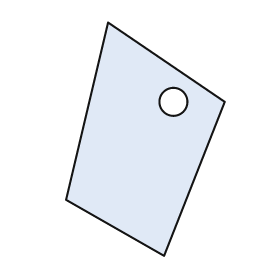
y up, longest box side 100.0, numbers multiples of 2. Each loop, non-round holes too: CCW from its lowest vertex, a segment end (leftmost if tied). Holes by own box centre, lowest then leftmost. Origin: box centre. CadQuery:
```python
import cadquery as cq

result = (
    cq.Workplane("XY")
    .moveTo(8.0, -50.0)
    .lineTo(34.0, 16.0)
    .lineTo(-16.0, 50.0)
    .lineTo(-34.0, -26.0)
    .close()
    .moveTo(12.0, 16.0)
    .circle(6.0)
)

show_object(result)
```